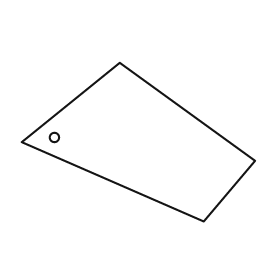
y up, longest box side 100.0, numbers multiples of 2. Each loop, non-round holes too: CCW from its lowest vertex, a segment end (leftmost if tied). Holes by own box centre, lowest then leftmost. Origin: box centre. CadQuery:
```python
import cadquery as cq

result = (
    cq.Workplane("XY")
    .moveTo(28.0, -34.0)
    .lineTo(50.0, -8.0)
    .lineTo(-8.0, 34.0)
    .lineTo(-50.0, 0.0)
    .close()
    .moveTo(-36.0, 2.0)
    .circle(2.0)
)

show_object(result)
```